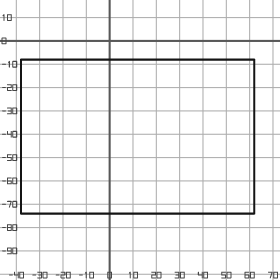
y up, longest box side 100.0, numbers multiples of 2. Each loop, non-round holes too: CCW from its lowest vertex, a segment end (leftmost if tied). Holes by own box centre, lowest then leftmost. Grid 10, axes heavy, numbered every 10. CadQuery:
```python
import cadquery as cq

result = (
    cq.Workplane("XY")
    .moveTo(-38.0, -74.0)
    .lineTo(62.0, -74.0)
    .lineTo(62.0, -8.0)
    .lineTo(-38.0, -8.0)
    .close()
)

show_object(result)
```